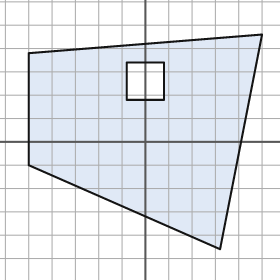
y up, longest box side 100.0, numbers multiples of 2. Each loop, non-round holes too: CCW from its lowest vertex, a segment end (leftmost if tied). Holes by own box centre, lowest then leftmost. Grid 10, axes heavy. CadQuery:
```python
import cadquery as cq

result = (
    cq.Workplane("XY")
    .moveTo(32.0, -46.0)
    .lineTo(50.0, 46.0)
    .lineTo(-50.0, 38.0)
    .lineTo(-50.0, -10.0)
    .close()
    .moveTo(-8.0, 18.0)
    .lineTo(8.0, 18.0)
    .lineTo(8.0, 34.0)
    .lineTo(-8.0, 34.0)
    .close()
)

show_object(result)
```